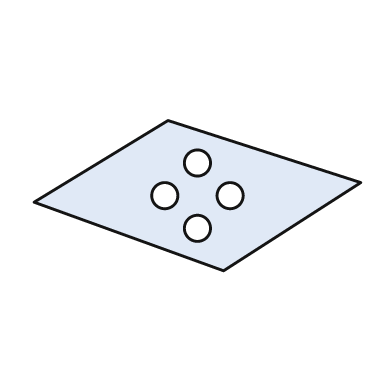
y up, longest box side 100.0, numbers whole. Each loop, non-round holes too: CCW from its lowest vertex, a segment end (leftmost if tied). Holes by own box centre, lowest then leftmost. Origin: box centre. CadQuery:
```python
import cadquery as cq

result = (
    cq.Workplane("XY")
    .moveTo(8.0, -23.0)
    .lineTo(50.0, 4.0)
    .lineTo(-9.0, 23.0)
    .lineTo(-50.0, -2.0)
    .close()
    .moveTo(0.0, -10.0)
    .circle(4.0)
    .moveTo(-10.0, 0.0)
    .circle(4.0)
    .moveTo(10.0, 0.0)
    .circle(4.0)
    .moveTo(0.0, 10.0)
    .circle(4.0)
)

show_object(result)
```